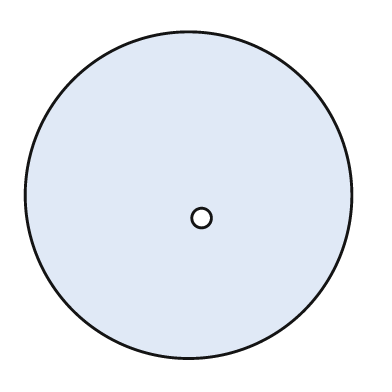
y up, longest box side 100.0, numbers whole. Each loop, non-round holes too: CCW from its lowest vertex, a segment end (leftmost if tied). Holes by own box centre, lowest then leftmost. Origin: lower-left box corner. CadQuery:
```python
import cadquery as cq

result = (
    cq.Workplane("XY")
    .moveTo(50.0, 50.0)
    .circle(50.0)
    .moveTo(54.0, 43.0)
    .circle(3.0)
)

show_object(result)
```